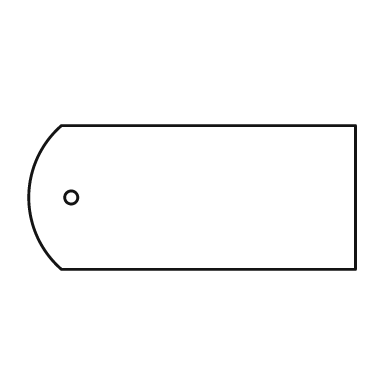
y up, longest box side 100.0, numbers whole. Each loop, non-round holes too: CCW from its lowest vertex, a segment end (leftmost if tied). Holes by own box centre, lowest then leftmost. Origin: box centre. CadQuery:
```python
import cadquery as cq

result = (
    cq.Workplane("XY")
    .moveTo(-40.0, -22.0)
    .lineTo(50.0, -22.0)
    .lineTo(50.0, 22.0)
    .lineTo(-40.0, 22.0)
    .threePointArc((-50.0, 0.0), (-40.0, -22.0))
    .close()
    .moveTo(-37.0, 0.0)
    .circle(2.0)
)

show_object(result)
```